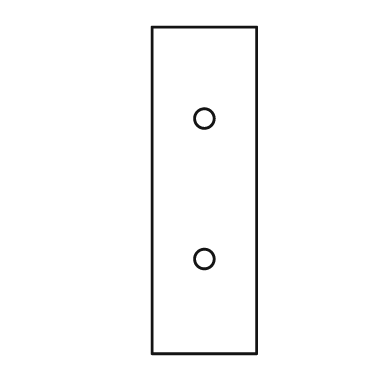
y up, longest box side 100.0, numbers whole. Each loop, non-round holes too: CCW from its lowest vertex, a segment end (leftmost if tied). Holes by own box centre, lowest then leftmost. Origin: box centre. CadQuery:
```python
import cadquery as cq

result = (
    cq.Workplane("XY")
    .moveTo(-16.0, -50.0)
    .lineTo(16.0, -50.0)
    .lineTo(16.0, 50.0)
    .lineTo(-16.0, 50.0)
    .close()
    .moveTo(0.0, -21.0)
    .circle(3.0)
    .moveTo(0.0, 22.0)
    .circle(3.0)
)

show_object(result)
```